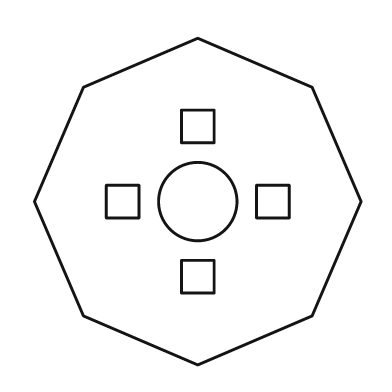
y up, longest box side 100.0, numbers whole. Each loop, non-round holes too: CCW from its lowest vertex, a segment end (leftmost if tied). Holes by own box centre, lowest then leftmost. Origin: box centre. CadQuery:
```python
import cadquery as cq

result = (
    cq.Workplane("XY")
    .moveTo(0.0, -50.0)
    .lineTo(35.0, -35.0)
    .lineTo(50.0, 0.0)
    .lineTo(35.0, 35.0)
    .lineTo(0.0, 50.0)
    .lineTo(-35.0, 35.0)
    .lineTo(-50.0, 0.0)
    .lineTo(-35.0, -35.0)
    .close()
    .moveTo(-5.0, -28.0)
    .lineTo(5.0, -28.0)
    .lineTo(5.0, -18.0)
    .lineTo(-5.0, -18.0)
    .close()
    .moveTo(-28.0, -5.0)
    .lineTo(-18.0, -5.0)
    .lineTo(-18.0, 5.0)
    .lineTo(-28.0, 5.0)
    .close()
    .moveTo(0.0, 0.0)
    .circle(12.0)
    .moveTo(18.0, -5.0)
    .lineTo(28.0, -5.0)
    .lineTo(28.0, 5.0)
    .lineTo(18.0, 5.0)
    .close()
    .moveTo(-5.0, 18.0)
    .lineTo(5.0, 18.0)
    .lineTo(5.0, 28.0)
    .lineTo(-5.0, 28.0)
    .close()
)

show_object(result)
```